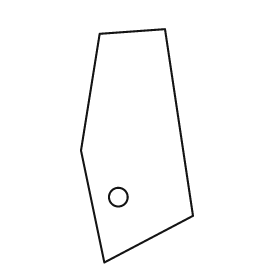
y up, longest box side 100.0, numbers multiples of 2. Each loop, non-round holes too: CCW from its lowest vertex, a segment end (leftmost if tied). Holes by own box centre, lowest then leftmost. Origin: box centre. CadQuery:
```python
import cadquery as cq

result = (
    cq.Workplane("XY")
    .moveTo(-14.0, -50.0)
    .lineTo(24.0, -30.0)
    .lineTo(12.0, 50.0)
    .lineTo(-16.0, 48.0)
    .lineTo(-24.0, -2.0)
    .close()
    .moveTo(-8.0, -22.0)
    .circle(4.0)
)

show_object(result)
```